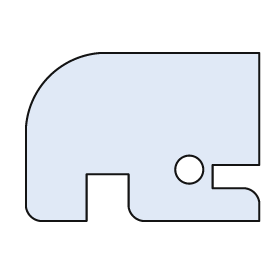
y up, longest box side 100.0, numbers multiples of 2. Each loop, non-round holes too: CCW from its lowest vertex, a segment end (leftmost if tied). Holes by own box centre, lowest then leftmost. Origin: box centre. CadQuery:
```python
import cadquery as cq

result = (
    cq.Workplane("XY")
    .moveTo(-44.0, -36.0)
    .lineTo(-24.0, -36.0)
    .lineTo(-24.0, -16.0)
    .lineTo(-6.0, -16.0)
    .lineTo(-6.0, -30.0)
    .threePointArc((-4.0, -34.0), (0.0, -36.0))
    .lineTo(50.0, -36.0)
    .lineTo(50.0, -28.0)
    .threePointArc((48.0, -24.0), (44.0, -22.0))
    .lineTo(30.0, -22.0)
    .lineTo(30.0, -12.0)
    .lineTo(50.0, -12.0)
    .lineTo(50.0, 36.0)
    .lineTo(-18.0, 36.0)
    .threePointArc((-40.0, 26.0), (-50.0, 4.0))
    .lineTo(-50.0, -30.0)
    .threePointArc((-48.0, -34.0), (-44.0, -36.0))
    .close()
    .moveTo(20.0, -14.0)
    .circle(6.0)
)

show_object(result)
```